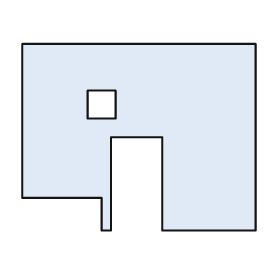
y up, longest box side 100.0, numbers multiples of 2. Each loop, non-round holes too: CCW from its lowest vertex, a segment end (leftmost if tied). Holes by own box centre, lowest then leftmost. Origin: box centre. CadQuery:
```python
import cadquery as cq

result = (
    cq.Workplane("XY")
    .moveTo(-16.0, -40.0)
    .lineTo(-12.0, -40.0)
    .lineTo(-12.0, 0.0)
    .lineTo(10.0, 0.0)
    .lineTo(10.0, -40.0)
    .lineTo(50.0, -40.0)
    .lineTo(50.0, 40.0)
    .lineTo(-50.0, 40.0)
    .lineTo(-50.0, -26.0)
    .lineTo(-16.0, -26.0)
    .close()
    .moveTo(-22.0, 8.0)
    .lineTo(-10.0, 8.0)
    .lineTo(-10.0, 20.0)
    .lineTo(-22.0, 20.0)
    .close()
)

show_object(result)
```